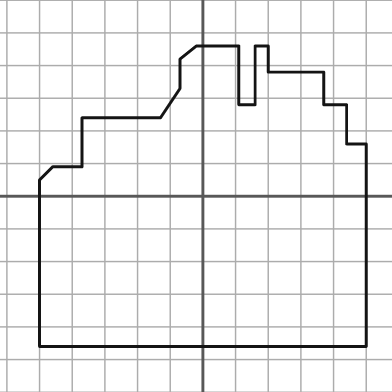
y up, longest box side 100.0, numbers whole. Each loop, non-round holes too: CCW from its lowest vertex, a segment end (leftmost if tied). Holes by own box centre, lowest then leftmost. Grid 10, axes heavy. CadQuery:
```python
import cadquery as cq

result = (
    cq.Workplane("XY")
    .moveTo(-50.0, -46.0)
    .lineTo(50.0, -46.0)
    .lineTo(50.0, 16.0)
    .lineTo(44.0, 16.0)
    .lineTo(44.0, 28.0)
    .lineTo(37.0, 28.0)
    .lineTo(37.0, 38.0)
    .lineTo(20.0, 38.0)
    .lineTo(20.0, 46.0)
    .lineTo(16.0, 46.0)
    .lineTo(16.0, 28.0)
    .lineTo(11.0, 28.0)
    .lineTo(11.0, 46.0)
    .lineTo(-2.0, 46.0)
    .lineTo(-7.0, 42.0)
    .lineTo(-7.0, 33.0)
    .lineTo(-13.0, 24.0)
    .lineTo(-37.0, 24.0)
    .lineTo(-37.0, 9.0)
    .lineTo(-46.0, 9.0)
    .lineTo(-50.0, 5.0)
    .close()
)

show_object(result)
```